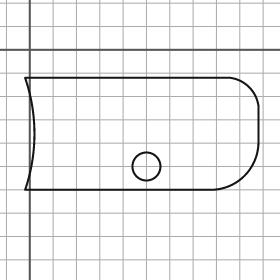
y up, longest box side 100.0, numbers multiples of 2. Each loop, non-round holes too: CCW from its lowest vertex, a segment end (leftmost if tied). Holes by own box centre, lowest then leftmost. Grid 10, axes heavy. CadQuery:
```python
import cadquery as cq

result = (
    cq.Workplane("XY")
    .moveTo(-2.0, -60.0)
    .lineTo(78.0, -60.0)
    .threePointArc((92.0, -54.0), (98.0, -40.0))
    .lineTo(98.0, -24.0)
    .threePointArc((94.0, -16.0), (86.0, -12.0))
    .lineTo(-2.0, -12.0)
    .threePointArc((2.0, -36.0), (-2.0, -60.0))
    .close()
    .moveTo(50.0, -50.0)
    .circle(6.0)
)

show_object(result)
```